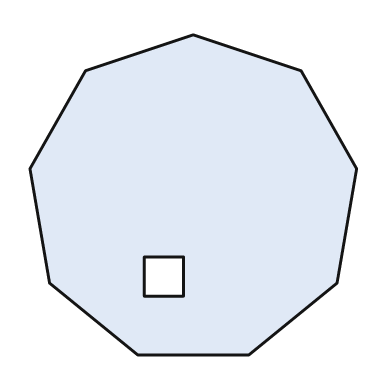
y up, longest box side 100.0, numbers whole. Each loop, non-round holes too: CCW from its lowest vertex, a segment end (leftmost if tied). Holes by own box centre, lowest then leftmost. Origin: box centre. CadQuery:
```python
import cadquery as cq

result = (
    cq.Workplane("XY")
    .moveTo(-17.0, -49.0)
    .lineTo(17.0, -49.0)
    .lineTo(44.0, -27.0)
    .lineTo(50.0, 8.0)
    .lineTo(33.0, 38.0)
    .lineTo(0.0, 49.0)
    .lineTo(-33.0, 38.0)
    .lineTo(-50.0, 8.0)
    .lineTo(-44.0, -27.0)
    .close()
    .moveTo(-15.0, -31.0)
    .lineTo(-3.0, -31.0)
    .lineTo(-3.0, -19.0)
    .lineTo(-15.0, -19.0)
    .close()
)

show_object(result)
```